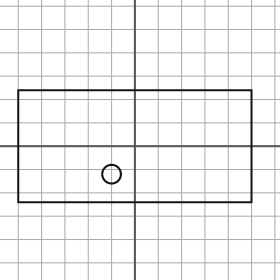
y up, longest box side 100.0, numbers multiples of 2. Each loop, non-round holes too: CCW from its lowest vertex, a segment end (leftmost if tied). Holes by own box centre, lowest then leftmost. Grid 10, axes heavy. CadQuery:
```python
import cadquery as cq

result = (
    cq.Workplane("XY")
    .moveTo(-50.0, -24.0)
    .lineTo(50.0, -24.0)
    .lineTo(50.0, 24.0)
    .lineTo(-50.0, 24.0)
    .close()
    .moveTo(-10.0, -12.0)
    .circle(4.0)
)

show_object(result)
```